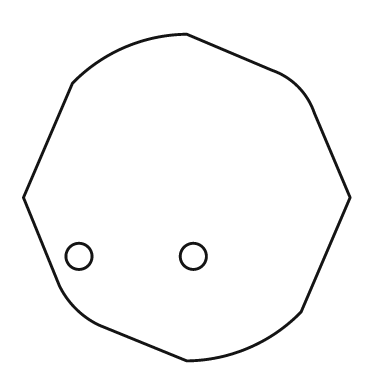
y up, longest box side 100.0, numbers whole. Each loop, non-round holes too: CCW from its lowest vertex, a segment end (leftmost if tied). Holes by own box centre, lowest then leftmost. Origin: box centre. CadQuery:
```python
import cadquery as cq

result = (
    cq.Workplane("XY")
    .moveTo(0.0, -50.0)
    .threePointArc((19.0, -46.0), (35.0, -35.0))
    .lineTo(50.0, 0.0)
    .lineTo(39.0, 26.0)
    .threePointArc((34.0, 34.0), (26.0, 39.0))
    .lineTo(0.0, 50.0)
    .threePointArc((-19.0, 46.0), (-35.0, 35.0))
    .lineTo(-50.0, 0.0)
    .lineTo(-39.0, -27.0)
    .threePointArc((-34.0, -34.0), (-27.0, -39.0))
    .close()
    .moveTo(-33.0, -18.0)
    .circle(4.0)
    .moveTo(2.0, -18.0)
    .circle(4.0)
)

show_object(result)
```